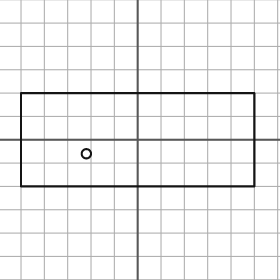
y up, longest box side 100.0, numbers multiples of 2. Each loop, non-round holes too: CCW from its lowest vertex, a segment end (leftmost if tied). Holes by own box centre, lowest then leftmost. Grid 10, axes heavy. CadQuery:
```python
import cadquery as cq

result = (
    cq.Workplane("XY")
    .moveTo(-50.0, -20.0)
    .lineTo(50.0, -20.0)
    .lineTo(50.0, 20.0)
    .lineTo(-50.0, 20.0)
    .close()
    .moveTo(-22.0, -6.0)
    .circle(2.0)
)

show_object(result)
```